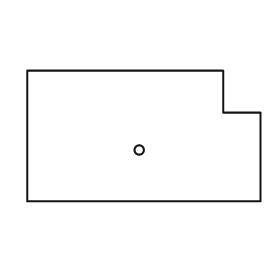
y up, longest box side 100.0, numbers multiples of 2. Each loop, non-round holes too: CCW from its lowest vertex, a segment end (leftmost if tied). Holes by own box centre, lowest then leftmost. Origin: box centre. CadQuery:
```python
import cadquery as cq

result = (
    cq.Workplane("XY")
    .moveTo(-50.0, -28.0)
    .lineTo(50.0, -28.0)
    .lineTo(50.0, 10.0)
    .lineTo(34.0, 10.0)
    .lineTo(34.0, 28.0)
    .lineTo(-50.0, 28.0)
    .close()
    .moveTo(-2.0, -6.0)
    .circle(2.0)
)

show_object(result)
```